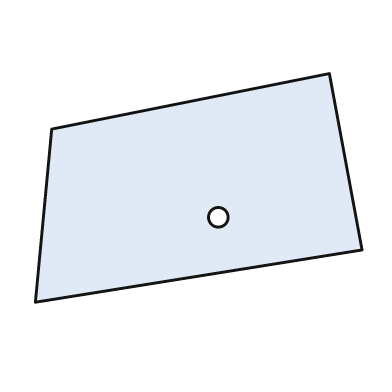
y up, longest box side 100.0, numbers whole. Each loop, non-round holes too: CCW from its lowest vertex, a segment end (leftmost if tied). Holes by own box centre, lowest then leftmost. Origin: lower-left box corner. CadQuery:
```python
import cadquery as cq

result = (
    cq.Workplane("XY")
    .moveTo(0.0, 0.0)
    .lineTo(100.0, 16.0)
    .lineTo(90.0, 70.0)
    .lineTo(5.0, 53.0)
    .close()
    .moveTo(56.0, 26.0)
    .circle(3.0)
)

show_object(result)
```